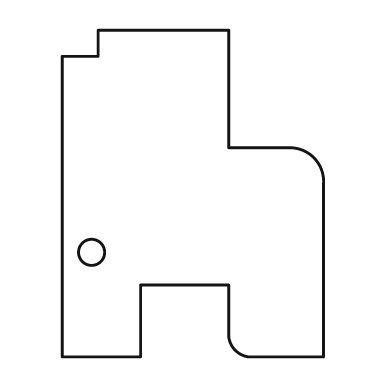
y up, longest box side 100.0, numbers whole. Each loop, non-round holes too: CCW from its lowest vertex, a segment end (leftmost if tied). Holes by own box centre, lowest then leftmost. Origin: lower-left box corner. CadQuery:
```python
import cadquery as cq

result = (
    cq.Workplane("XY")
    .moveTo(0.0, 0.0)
    .lineTo(24.0, 0.0)
    .lineTo(24.0, 22.0)
    .lineTo(51.0, 22.0)
    .lineTo(51.0, 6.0)
    .threePointArc((53.0, 2.0), (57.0, 0.0))
    .lineTo(80.0, 0.0)
    .lineTo(80.0, 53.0)
    .threePointArc((77.0, 61.0), (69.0, 64.0))
    .lineTo(51.0, 64.0)
    .lineTo(51.0, 100.0)
    .lineTo(11.0, 100.0)
    .lineTo(11.0, 92.0)
    .lineTo(0.0, 92.0)
    .close()
    .moveTo(9.0, 32.0)
    .circle(4.0)
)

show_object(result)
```